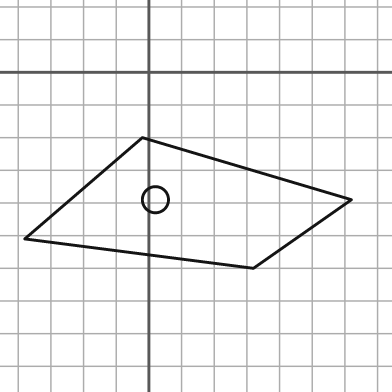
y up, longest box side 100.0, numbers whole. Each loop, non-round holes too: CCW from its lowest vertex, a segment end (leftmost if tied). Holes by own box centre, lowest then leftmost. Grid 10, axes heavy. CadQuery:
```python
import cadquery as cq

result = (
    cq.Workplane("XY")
    .moveTo(32.0, -60.0)
    .lineTo(62.0, -39.0)
    .lineTo(-2.0, -20.0)
    .lineTo(-38.0, -51.0)
    .close()
    .moveTo(2.0, -39.0)
    .circle(4.0)
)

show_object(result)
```